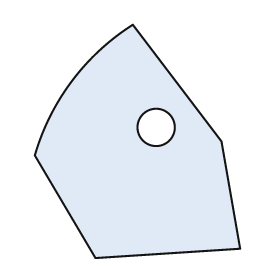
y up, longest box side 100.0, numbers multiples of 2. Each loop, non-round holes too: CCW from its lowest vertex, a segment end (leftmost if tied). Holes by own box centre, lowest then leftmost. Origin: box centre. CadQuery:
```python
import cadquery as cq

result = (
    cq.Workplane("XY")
    .moveTo(-18.0, -50.0)
    .lineTo(44.0, -46.0)
    .lineTo(36.0, 0.0)
    .lineTo(-2.0, 50.0)
    .threePointArc((-28.0, 26.0), (-44.0, -6.0))
    .close()
    .moveTo(8.0, 6.0)
    .circle(8.0)
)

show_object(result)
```